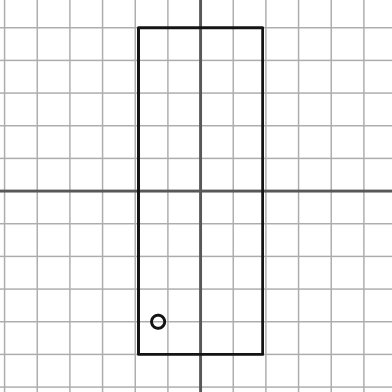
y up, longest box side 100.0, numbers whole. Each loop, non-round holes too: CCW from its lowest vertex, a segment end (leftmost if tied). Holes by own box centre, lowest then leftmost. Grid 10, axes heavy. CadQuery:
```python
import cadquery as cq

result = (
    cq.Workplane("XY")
    .moveTo(-19.0, -50.0)
    .lineTo(19.0, -50.0)
    .lineTo(19.0, 50.0)
    .lineTo(-19.0, 50.0)
    .close()
    .moveTo(-13.0, -40.0)
    .circle(2.0)
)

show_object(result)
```